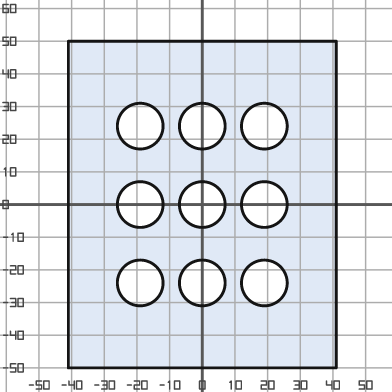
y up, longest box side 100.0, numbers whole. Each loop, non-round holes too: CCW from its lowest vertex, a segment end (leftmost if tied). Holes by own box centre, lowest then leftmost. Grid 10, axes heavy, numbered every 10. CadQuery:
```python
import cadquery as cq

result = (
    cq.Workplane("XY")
    .moveTo(-41.0, -50.0)
    .lineTo(41.0, -50.0)
    .lineTo(41.0, 50.0)
    .lineTo(-41.0, 50.0)
    .close()
    .moveTo(-19.0, -24.0)
    .circle(7.0)
    .moveTo(0.0, -24.0)
    .circle(7.0)
    .moveTo(19.0, -24.0)
    .circle(7.0)
    .moveTo(-19.0, 0.0)
    .circle(7.0)
    .moveTo(0.0, 0.0)
    .circle(7.0)
    .moveTo(19.0, 0.0)
    .circle(7.0)
    .moveTo(-19.0, 24.0)
    .circle(7.0)
    .moveTo(0.0, 24.0)
    .circle(7.0)
    .moveTo(19.0, 24.0)
    .circle(7.0)
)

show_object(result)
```